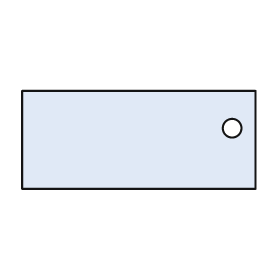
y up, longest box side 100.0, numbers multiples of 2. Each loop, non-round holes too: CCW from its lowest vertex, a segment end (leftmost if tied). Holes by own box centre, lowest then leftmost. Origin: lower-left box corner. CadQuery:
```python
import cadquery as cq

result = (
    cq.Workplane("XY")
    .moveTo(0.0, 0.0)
    .lineTo(100.0, 0.0)
    .lineTo(100.0, 42.0)
    .lineTo(0.0, 42.0)
    .close()
    .moveTo(90.0, 26.0)
    .circle(4.0)
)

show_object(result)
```